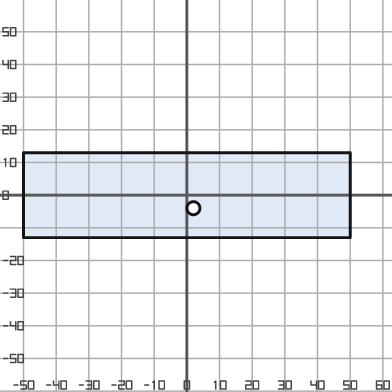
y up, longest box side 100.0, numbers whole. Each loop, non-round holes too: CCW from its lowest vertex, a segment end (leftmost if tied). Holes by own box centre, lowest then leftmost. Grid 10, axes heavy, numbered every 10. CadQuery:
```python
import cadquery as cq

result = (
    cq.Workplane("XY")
    .moveTo(-50.0, -13.0)
    .lineTo(50.0, -13.0)
    .lineTo(50.0, 13.0)
    .lineTo(-50.0, 13.0)
    .close()
    .moveTo(2.0, -4.0)
    .circle(2.0)
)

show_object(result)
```